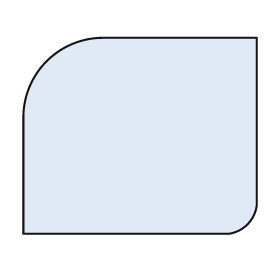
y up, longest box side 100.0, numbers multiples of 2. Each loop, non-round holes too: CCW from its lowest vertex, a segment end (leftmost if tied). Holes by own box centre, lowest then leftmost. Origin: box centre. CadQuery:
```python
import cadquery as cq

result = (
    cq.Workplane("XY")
    .moveTo(-50.0, -42.0)
    .lineTo(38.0, -42.0)
    .threePointArc((46.0, -38.0), (50.0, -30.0))
    .lineTo(50.0, 42.0)
    .lineTo(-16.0, 42.0)
    .threePointArc((-40.0, 32.0), (-50.0, 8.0))
    .close()
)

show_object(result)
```